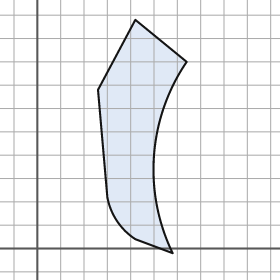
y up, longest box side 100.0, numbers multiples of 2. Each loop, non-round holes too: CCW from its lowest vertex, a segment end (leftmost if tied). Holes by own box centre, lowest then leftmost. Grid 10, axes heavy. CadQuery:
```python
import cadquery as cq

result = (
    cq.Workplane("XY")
    .moveTo(58.0, -2.0)
    .threePointArc((50.0, 40.0), (64.0, 80.0))
    .lineTo(42.0, 98.0)
    .lineTo(26.0, 68.0)
    .lineTo(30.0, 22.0)
    .threePointArc((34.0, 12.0), (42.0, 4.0))
    .close()
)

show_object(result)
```